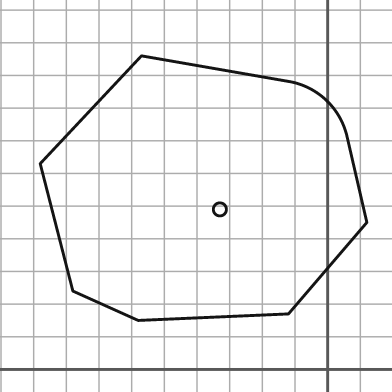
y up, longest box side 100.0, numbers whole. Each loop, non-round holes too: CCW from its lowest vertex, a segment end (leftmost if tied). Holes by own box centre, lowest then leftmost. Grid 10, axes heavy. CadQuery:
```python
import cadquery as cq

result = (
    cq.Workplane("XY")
    .moveTo(-58.0, 15.0)
    .lineTo(-12.0, 17.0)
    .lineTo(12.0, 45.0)
    .lineTo(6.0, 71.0)
    .threePointArc((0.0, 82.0), (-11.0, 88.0))
    .lineTo(-57.0, 96.0)
    .lineTo(-88.0, 63.0)
    .lineTo(-78.0, 24.0)
    .close()
    .moveTo(-33.0, 49.0)
    .circle(2.0)
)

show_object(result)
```